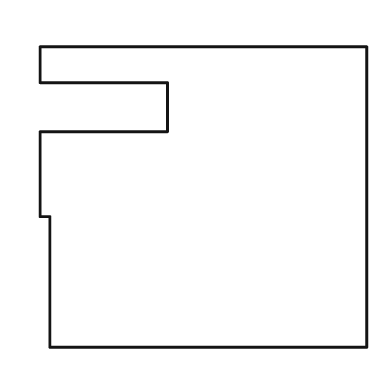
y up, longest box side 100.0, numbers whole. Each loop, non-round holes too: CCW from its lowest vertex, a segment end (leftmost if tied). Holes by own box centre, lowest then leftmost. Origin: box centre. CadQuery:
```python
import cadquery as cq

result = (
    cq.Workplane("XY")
    .moveTo(-47.0, -46.0)
    .lineTo(50.0, -46.0)
    .lineTo(50.0, 46.0)
    .lineTo(-50.0, 46.0)
    .lineTo(-50.0, 35.0)
    .lineTo(-11.0, 35.0)
    .lineTo(-11.0, 20.0)
    .lineTo(-50.0, 20.0)
    .lineTo(-50.0, -6.0)
    .lineTo(-47.0, -6.0)
    .close()
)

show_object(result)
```